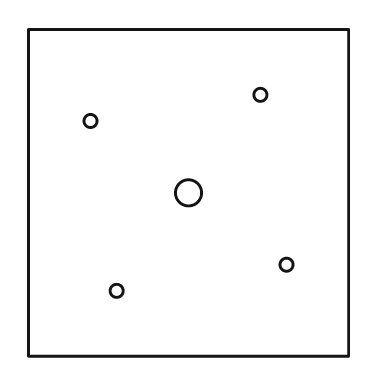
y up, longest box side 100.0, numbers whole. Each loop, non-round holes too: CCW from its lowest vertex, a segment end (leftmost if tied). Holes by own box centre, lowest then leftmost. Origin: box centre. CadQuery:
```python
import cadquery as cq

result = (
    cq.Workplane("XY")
    .moveTo(-49.0, -50.0)
    .lineTo(49.0, -50.0)
    .lineTo(49.0, 50.0)
    .lineTo(-49.0, 50.0)
    .close()
    .moveTo(-22.0, -30.0)
    .circle(2.0)
    .moveTo(30.0, -22.0)
    .circle(2.0)
    .moveTo(0.0, 0.0)
    .circle(4.0)
    .moveTo(-30.0, 22.0)
    .circle(2.0)
    .moveTo(22.0, 30.0)
    .circle(2.0)
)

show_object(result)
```